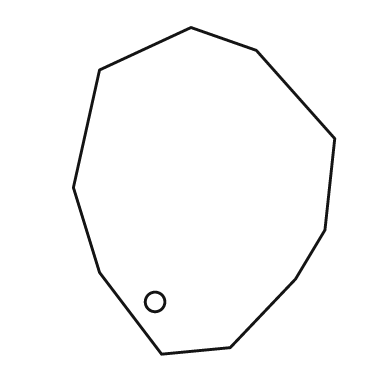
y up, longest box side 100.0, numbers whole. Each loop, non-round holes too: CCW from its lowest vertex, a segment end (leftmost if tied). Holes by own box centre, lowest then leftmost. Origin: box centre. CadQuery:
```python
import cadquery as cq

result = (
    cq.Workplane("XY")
    .moveTo(-13.0, -50.0)
    .lineTo(8.0, -48.0)
    .lineTo(28.0, -27.0)
    .lineTo(37.0, -12.0)
    .lineTo(40.0, 16.0)
    .lineTo(16.0, 43.0)
    .lineTo(-4.0, 50.0)
    .lineTo(-32.0, 37.0)
    .lineTo(-40.0, 1.0)
    .lineTo(-32.0, -25.0)
    .close()
    .moveTo(-15.0, -34.0)
    .circle(3.0)
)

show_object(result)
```